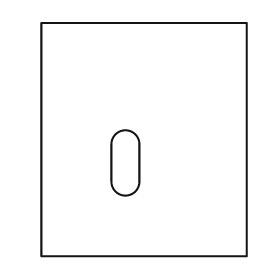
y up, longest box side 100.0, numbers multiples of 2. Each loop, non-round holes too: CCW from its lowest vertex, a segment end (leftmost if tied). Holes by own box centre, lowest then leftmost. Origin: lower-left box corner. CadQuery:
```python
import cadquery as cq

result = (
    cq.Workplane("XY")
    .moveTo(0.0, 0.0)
    .lineTo(88.0, 0.0)
    .lineTo(88.0, 100.0)
    .lineTo(0.0, 100.0)
    .close()
    .moveTo(30.0, 32.0)
    .threePointArc((36.0, 26.0), (42.0, 32.0))
    .lineTo(42.0, 48.0)
    .threePointArc((36.0, 54.0), (30.0, 48.0))
    .close()
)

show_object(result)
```